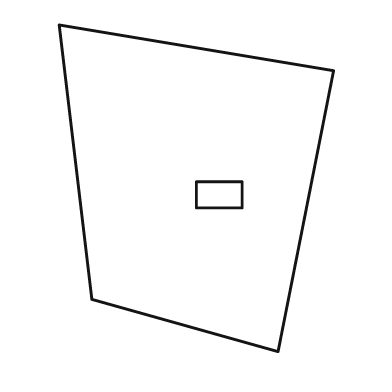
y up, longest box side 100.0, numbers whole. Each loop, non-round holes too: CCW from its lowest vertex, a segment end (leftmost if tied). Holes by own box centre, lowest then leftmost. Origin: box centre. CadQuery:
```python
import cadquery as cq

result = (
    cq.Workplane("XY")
    .moveTo(25.0, -50.0)
    .lineTo(42.0, 36.0)
    .lineTo(-42.0, 50.0)
    .lineTo(-32.0, -34.0)
    .close()
    .moveTo(0.0, -6.0)
    .lineTo(14.0, -6.0)
    .lineTo(14.0, 2.0)
    .lineTo(0.0, 2.0)
    .close()
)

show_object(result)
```